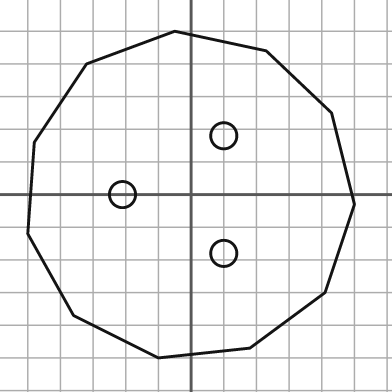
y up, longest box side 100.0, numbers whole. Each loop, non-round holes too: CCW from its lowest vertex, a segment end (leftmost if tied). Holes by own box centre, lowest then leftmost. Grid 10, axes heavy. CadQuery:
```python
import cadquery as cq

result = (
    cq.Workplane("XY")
    .moveTo(-10.0, -50.0)
    .lineTo(18.0, -47.0)
    .lineTo(41.0, -30.0)
    .lineTo(50.0, -3.0)
    .lineTo(43.0, 25.0)
    .lineTo(23.0, 44.0)
    .lineTo(-5.0, 50.0)
    .lineTo(-32.0, 40.0)
    .lineTo(-48.0, 16.0)
    .lineTo(-50.0, -12.0)
    .lineTo(-36.0, -37.0)
    .close()
    .moveTo(10.0, -18.0)
    .circle(4.0)
    .moveTo(-21.0, 0.0)
    .circle(4.0)
    .moveTo(10.0, 18.0)
    .circle(4.0)
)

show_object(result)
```